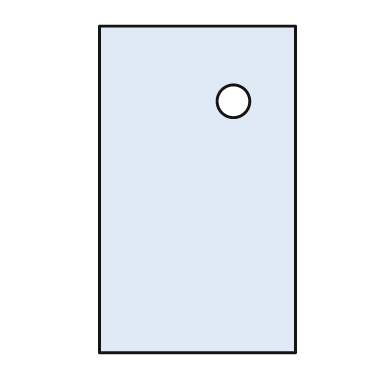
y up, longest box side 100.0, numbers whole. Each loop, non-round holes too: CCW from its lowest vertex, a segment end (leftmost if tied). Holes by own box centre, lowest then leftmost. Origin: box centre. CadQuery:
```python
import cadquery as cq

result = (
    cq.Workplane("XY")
    .moveTo(-30.0, -50.0)
    .lineTo(30.0, -50.0)
    .lineTo(30.0, 50.0)
    .lineTo(-30.0, 50.0)
    .close()
    .moveTo(11.0, 27.0)
    .circle(5.0)
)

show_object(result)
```